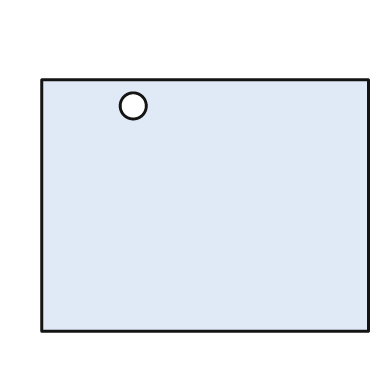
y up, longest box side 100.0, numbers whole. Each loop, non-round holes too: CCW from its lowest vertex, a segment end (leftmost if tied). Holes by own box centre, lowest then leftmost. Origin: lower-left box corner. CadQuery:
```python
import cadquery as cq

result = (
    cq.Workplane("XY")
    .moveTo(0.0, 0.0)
    .lineTo(100.0, 0.0)
    .lineTo(100.0, 77.0)
    .lineTo(0.0, 77.0)
    .close()
    .moveTo(28.0, 69.0)
    .circle(4.0)
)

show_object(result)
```